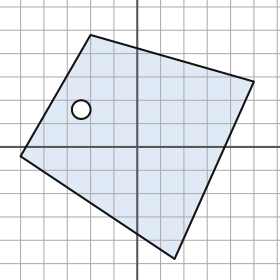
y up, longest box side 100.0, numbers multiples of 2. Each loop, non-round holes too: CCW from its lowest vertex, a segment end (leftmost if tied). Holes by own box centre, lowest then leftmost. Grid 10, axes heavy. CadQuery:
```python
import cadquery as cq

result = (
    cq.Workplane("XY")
    .moveTo(16.0, -48.0)
    .lineTo(50.0, 28.0)
    .lineTo(-20.0, 48.0)
    .lineTo(-50.0, -4.0)
    .close()
    .moveTo(-24.0, 16.0)
    .circle(4.0)
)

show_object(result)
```